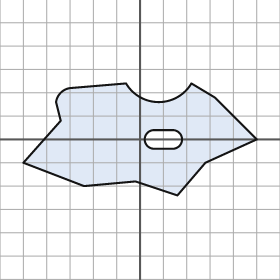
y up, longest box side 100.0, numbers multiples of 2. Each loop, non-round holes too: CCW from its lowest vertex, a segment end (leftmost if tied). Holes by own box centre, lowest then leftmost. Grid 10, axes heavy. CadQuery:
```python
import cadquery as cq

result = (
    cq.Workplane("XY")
    .moveTo(16.0, -24.0)
    .lineTo(28.0, -10.0)
    .lineTo(50.0, 0.0)
    .lineTo(32.0, 18.0)
    .lineTo(22.0, 24.0)
    .threePointArc((8.0, 16.0), (-6.0, 24.0))
    .lineTo(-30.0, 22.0)
    .threePointArc((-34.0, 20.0), (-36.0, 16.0))
    .lineTo(-34.0, 8.0)
    .lineTo(-50.0, -10.0)
    .lineTo(-24.0, -20.0)
    .lineTo(-2.0, -18.0)
    .close()
    .moveTo(6.0, -4.0)
    .lineTo(14.0, -4.0)
    .threePointArc((18.0, 0.0), (14.0, 4.0))
    .lineTo(6.0, 4.0)
    .threePointArc((2.0, 0.0), (6.0, -4.0))
    .close()
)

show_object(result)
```